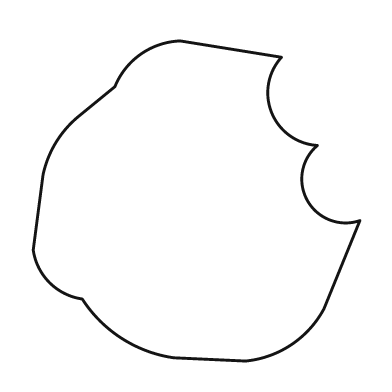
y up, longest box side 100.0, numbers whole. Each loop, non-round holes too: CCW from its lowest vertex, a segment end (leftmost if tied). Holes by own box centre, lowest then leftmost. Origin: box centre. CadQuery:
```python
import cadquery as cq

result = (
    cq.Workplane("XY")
    .moveTo(15.0, -49.0)
    .threePointArc((29.0, -44.0), (39.0, -33.0))
    .lineTo(50.0, -6.0)
    .threePointArc((34.0, 0.0), (37.0, 17.0))
    .threePointArc((23.0, 27.0), (26.0, 44.0))
    .lineTo(-5.0, 49.0)
    .threePointArc((-17.0, 45.0), (-25.0, 35.0))
    .lineTo(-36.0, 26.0)
    .threePointArc((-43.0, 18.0), (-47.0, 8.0))
    .lineTo(-50.0, -15.0)
    .threePointArc((-45.0, -25.0), (-35.0, -30.0))
    .threePointArc((-23.0, -42.0), (-7.0, -48.0))
    .close()
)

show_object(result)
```